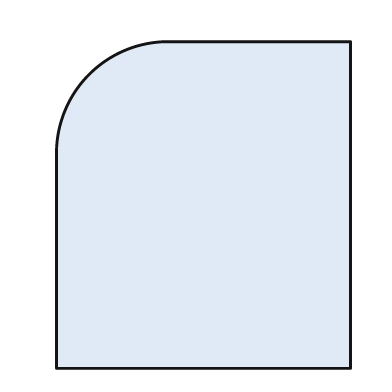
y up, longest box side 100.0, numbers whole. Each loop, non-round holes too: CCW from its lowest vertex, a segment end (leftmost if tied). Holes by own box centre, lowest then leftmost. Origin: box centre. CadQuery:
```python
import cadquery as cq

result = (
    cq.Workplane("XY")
    .moveTo(-45.0, -50.0)
    .lineTo(45.0, -50.0)
    .lineTo(45.0, 50.0)
    .lineTo(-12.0, 50.0)
    .threePointArc((-35.0, 40.0), (-45.0, 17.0))
    .close()
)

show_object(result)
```